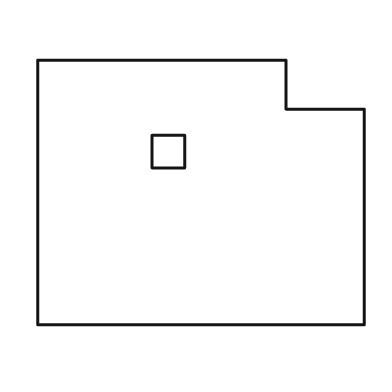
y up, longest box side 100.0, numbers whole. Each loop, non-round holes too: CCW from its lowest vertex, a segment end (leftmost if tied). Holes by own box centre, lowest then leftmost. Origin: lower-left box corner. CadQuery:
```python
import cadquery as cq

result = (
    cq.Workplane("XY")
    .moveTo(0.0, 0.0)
    .lineTo(100.0, 0.0)
    .lineTo(100.0, 66.0)
    .lineTo(76.0, 66.0)
    .lineTo(76.0, 81.0)
    .lineTo(0.0, 81.0)
    .close()
    .moveTo(35.0, 48.0)
    .lineTo(45.0, 48.0)
    .lineTo(45.0, 58.0)
    .lineTo(35.0, 58.0)
    .close()
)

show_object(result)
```